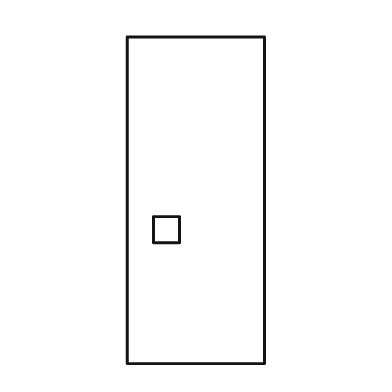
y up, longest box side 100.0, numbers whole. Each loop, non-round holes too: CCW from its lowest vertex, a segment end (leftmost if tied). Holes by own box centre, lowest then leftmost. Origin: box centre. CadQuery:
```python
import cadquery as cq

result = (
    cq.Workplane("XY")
    .moveTo(-21.0, -50.0)
    .lineTo(21.0, -50.0)
    .lineTo(21.0, 50.0)
    .lineTo(-21.0, 50.0)
    .close()
    .moveTo(-13.0, -13.0)
    .lineTo(-5.0, -13.0)
    .lineTo(-5.0, -5.0)
    .lineTo(-13.0, -5.0)
    .close()
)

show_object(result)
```